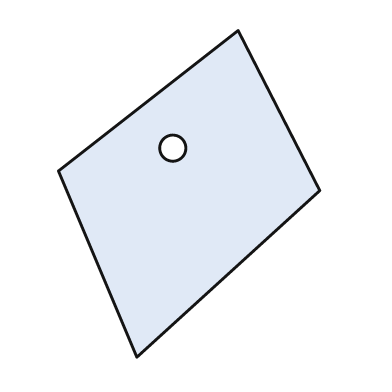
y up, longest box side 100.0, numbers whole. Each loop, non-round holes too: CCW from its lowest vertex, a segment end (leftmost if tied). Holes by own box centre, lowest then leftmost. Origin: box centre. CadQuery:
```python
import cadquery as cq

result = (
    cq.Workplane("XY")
    .moveTo(-16.0, -50.0)
    .lineTo(40.0, 1.0)
    .lineTo(15.0, 50.0)
    .lineTo(-40.0, 7.0)
    .close()
    .moveTo(-5.0, 14.0)
    .circle(4.0)
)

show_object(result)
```